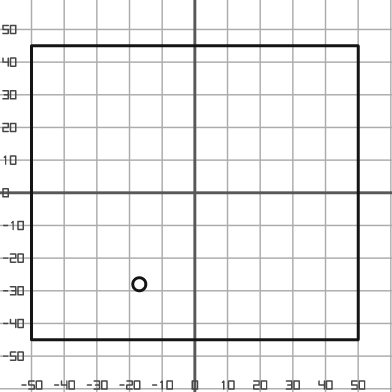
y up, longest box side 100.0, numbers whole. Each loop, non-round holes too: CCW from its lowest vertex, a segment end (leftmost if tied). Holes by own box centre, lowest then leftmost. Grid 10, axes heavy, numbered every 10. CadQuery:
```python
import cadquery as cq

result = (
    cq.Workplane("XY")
    .moveTo(-50.0, -45.0)
    .lineTo(50.0, -45.0)
    .lineTo(50.0, 45.0)
    .lineTo(-50.0, 45.0)
    .close()
    .moveTo(-17.0, -28.0)
    .circle(2.0)
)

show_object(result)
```